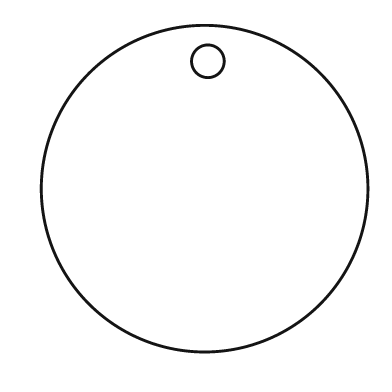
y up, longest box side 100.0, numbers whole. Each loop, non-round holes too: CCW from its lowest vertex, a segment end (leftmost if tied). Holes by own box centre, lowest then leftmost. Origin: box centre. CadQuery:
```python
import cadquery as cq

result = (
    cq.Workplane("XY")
    .moveTo(0.0, 0.0)
    .circle(50.0)
    .moveTo(1.0, 39.0)
    .circle(5.0)
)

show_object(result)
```